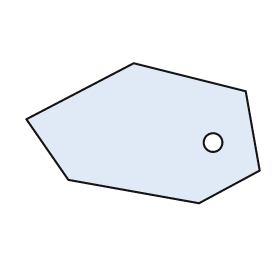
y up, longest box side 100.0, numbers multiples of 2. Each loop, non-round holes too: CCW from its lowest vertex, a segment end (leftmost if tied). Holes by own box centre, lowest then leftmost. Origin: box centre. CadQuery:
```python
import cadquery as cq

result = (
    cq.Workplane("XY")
    .moveTo(24.0, -30.0)
    .lineTo(50.0, -16.0)
    .lineTo(44.0, 18.0)
    .lineTo(-4.0, 30.0)
    .lineTo(-50.0, 6.0)
    .lineTo(-32.0, -20.0)
    .close()
    .moveTo(30.0, -4.0)
    .circle(4.0)
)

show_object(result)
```